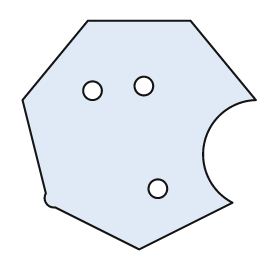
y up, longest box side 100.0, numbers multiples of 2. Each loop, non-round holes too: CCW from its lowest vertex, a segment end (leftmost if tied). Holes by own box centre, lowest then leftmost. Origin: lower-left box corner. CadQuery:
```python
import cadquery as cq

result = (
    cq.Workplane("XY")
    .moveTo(50.0, 0.0)
    .lineTo(90.0, 20.0)
    .threePointArc((78.0, 46.0), (100.0, 64.0))
    .lineTo(72.0, 98.0)
    .lineTo(28.0, 98.0)
    .lineTo(0.0, 64.0)
    .lineTo(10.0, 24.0)
    .threePointArc((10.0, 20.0), (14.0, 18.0))
    .close()
    .moveTo(58.0, 26.0)
    .circle(4.0)
    .moveTo(30.0, 68.0)
    .circle(4.0)
    .moveTo(52.0, 70.0)
    .circle(4.0)
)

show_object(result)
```